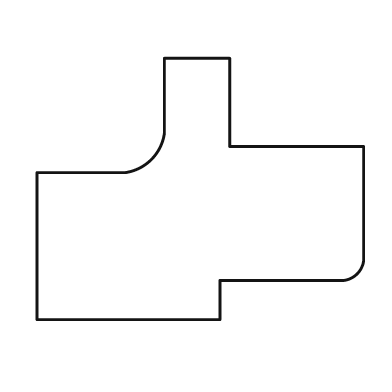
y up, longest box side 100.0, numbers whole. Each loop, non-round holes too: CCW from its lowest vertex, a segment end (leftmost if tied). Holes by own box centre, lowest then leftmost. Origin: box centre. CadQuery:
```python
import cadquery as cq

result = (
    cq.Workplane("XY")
    .moveTo(-50.0, -40.0)
    .lineTo(6.0, -40.0)
    .lineTo(6.0, -28.0)
    .lineTo(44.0, -28.0)
    .threePointArc((48.0, -26.0), (50.0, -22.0))
    .lineTo(50.0, 13.0)
    .lineTo(9.0, 13.0)
    .lineTo(9.0, 40.0)
    .lineTo(-11.0, 40.0)
    .lineTo(-11.0, 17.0)
    .threePointArc((-15.0, 9.0), (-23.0, 5.0))
    .lineTo(-50.0, 5.0)
    .close()
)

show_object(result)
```